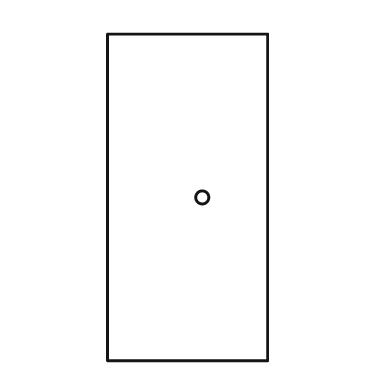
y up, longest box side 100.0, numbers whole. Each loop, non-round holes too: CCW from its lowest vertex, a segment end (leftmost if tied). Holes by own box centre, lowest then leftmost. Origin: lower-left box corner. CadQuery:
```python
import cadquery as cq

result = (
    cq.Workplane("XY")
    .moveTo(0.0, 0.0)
    .lineTo(49.0, 0.0)
    .lineTo(49.0, 100.0)
    .lineTo(0.0, 100.0)
    .close()
    .moveTo(29.0, 50.0)
    .circle(2.0)
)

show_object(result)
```